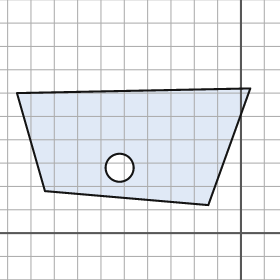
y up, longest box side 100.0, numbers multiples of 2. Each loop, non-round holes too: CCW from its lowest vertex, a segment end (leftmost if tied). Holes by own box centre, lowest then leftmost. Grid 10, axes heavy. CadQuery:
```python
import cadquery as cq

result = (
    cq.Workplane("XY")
    .moveTo(-14.0, 12.0)
    .lineTo(4.0, 62.0)
    .lineTo(-96.0, 60.0)
    .lineTo(-84.0, 18.0)
    .close()
    .moveTo(-52.0, 28.0)
    .circle(6.0)
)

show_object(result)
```